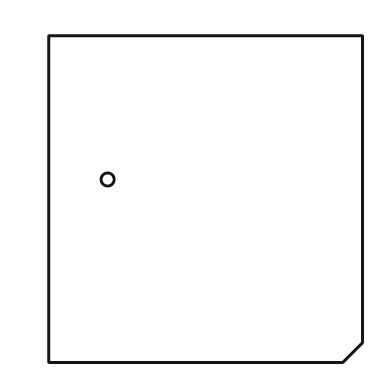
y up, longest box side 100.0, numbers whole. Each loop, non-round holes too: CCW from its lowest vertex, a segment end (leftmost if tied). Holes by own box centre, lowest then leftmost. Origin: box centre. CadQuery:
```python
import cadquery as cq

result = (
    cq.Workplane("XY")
    .moveTo(-48.0, -50.0)
    .lineTo(42.0, -50.0)
    .lineTo(48.0, -44.0)
    .lineTo(48.0, 50.0)
    .lineTo(-48.0, 50.0)
    .close()
    .moveTo(-30.0, 6.0)
    .circle(2.0)
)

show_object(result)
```